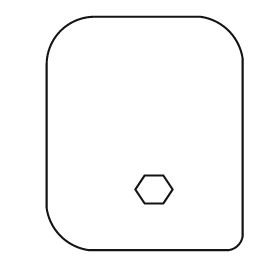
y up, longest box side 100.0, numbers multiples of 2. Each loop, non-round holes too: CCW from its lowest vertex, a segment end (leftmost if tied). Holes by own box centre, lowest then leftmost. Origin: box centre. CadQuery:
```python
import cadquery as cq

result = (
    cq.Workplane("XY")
    .moveTo(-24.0, -50.0)
    .lineTo(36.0, -50.0)
    .threePointArc((40.0, -48.0), (42.0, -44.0))
    .lineTo(42.0, 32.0)
    .threePointArc((36.0, 44.0), (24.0, 50.0))
    .lineTo(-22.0, 50.0)
    .threePointArc((-36.0, 44.0), (-42.0, 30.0))
    .lineTo(-42.0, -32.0)
    .threePointArc((-36.0, -44.0), (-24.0, -50.0))
    .close()
    .moveTo(0.0, -30.0)
    .lineTo(8.0, -30.0)
    .lineTo(12.0, -24.0)
    .lineTo(8.0, -18.0)
    .lineTo(0.0, -18.0)
    .lineTo(-4.0, -24.0)
    .close()
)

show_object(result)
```